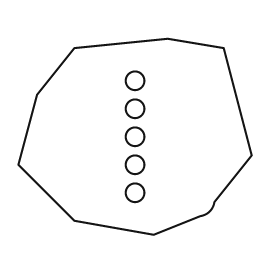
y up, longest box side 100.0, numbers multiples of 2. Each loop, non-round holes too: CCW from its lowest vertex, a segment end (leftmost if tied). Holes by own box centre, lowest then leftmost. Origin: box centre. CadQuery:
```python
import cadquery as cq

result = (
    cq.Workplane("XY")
    .moveTo(8.0, -42.0)
    .lineTo(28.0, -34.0)
    .threePointArc((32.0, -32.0), (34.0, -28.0))
    .lineTo(50.0, -8.0)
    .lineTo(38.0, 38.0)
    .lineTo(14.0, 42.0)
    .lineTo(-26.0, 38.0)
    .lineTo(-42.0, 18.0)
    .lineTo(-50.0, -12.0)
    .lineTo(-26.0, -36.0)
    .close()
    .moveTo(0.0, -24.0)
    .circle(4.0)
    .moveTo(0.0, -12.0)
    .circle(4.0)
    .moveTo(0.0, 0.0)
    .circle(4.0)
    .moveTo(0.0, 12.0)
    .circle(4.0)
    .moveTo(0.0, 24.0)
    .circle(4.0)
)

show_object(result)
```